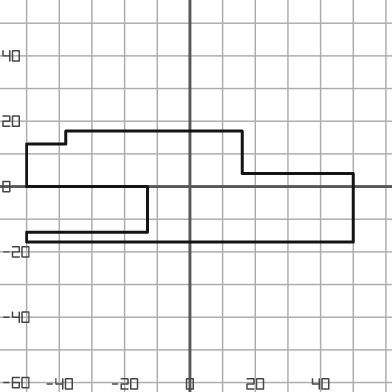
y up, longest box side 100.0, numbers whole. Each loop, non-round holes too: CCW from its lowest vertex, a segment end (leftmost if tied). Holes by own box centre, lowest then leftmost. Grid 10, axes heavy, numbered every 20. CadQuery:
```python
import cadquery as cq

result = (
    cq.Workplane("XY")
    .moveTo(-50.0, -17.0)
    .lineTo(50.0, -17.0)
    .lineTo(50.0, 4.0)
    .lineTo(16.0, 4.0)
    .lineTo(16.0, 17.0)
    .lineTo(-38.0, 17.0)
    .lineTo(-38.0, 13.0)
    .lineTo(-50.0, 13.0)
    .lineTo(-50.0, 0.0)
    .lineTo(-13.0, 0.0)
    .lineTo(-13.0, -14.0)
    .lineTo(-50.0, -14.0)
    .close()
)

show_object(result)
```